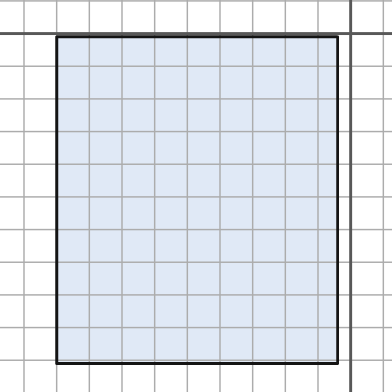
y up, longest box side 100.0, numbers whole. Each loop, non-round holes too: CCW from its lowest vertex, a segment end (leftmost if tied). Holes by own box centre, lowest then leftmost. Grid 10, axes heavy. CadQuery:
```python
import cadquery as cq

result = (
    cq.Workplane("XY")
    .moveTo(-90.0, -101.0)
    .lineTo(-4.0, -101.0)
    .lineTo(-4.0, -1.0)
    .lineTo(-90.0, -1.0)
    .close()
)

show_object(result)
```